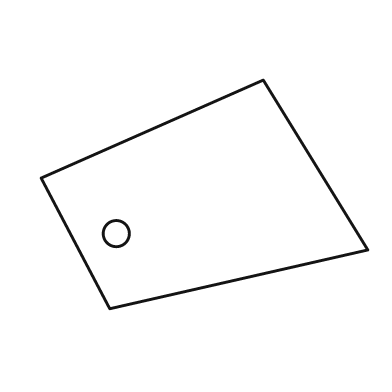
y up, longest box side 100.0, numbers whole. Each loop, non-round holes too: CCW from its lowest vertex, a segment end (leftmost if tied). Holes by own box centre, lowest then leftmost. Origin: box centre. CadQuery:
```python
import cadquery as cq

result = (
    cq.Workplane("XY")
    .moveTo(-29.0, -35.0)
    .lineTo(50.0, -17.0)
    .lineTo(18.0, 35.0)
    .lineTo(-50.0, 5.0)
    .close()
    .moveTo(-27.0, -12.0)
    .circle(4.0)
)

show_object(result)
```